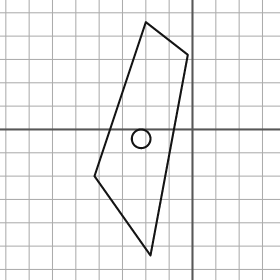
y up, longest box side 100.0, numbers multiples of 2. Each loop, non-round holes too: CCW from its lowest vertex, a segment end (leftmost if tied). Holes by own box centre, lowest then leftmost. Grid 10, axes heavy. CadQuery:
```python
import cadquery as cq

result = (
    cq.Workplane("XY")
    .moveTo(-18.0, -54.0)
    .lineTo(-2.0, 32.0)
    .lineTo(-20.0, 46.0)
    .lineTo(-42.0, -20.0)
    .close()
    .moveTo(-22.0, -4.0)
    .circle(4.0)
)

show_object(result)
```